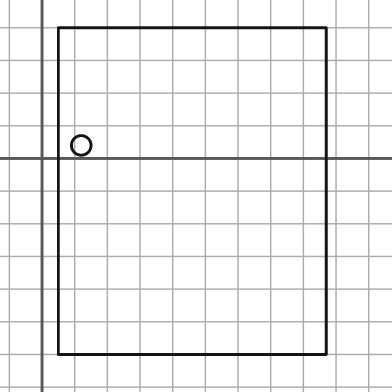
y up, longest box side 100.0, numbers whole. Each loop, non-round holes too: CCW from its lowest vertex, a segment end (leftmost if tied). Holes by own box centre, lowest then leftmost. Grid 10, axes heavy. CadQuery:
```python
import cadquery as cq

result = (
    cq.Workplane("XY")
    .moveTo(5.0, -60.0)
    .lineTo(87.0, -60.0)
    .lineTo(87.0, 40.0)
    .lineTo(5.0, 40.0)
    .close()
    .moveTo(12.0, 4.0)
    .circle(3.0)
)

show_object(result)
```